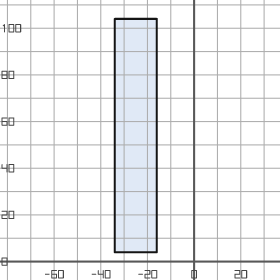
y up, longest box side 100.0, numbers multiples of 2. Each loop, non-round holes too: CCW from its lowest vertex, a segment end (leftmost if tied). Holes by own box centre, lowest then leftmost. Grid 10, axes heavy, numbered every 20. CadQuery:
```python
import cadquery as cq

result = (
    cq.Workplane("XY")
    .moveTo(-34.0, 4.0)
    .lineTo(-16.0, 4.0)
    .lineTo(-16.0, 104.0)
    .lineTo(-34.0, 104.0)
    .close()
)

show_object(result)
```